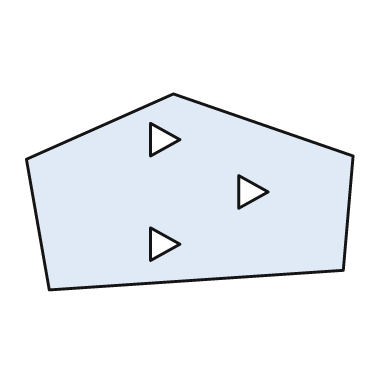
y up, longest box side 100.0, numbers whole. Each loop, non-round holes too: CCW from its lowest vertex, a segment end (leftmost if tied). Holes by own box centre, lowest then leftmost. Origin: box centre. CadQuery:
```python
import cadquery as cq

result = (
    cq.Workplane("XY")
    .moveTo(-43.0, -30.0)
    .lineTo(47.0, -24.0)
    .lineTo(50.0, 11.0)
    .lineTo(-5.0, 30.0)
    .lineTo(-50.0, 10.0)
    .close()
    .moveTo(-12.0, -21.0)
    .lineTo(-3.0, -16.0)
    .lineTo(-12.0, -11.0)
    .close()
    .moveTo(15.0, -5.0)
    .lineTo(24.0, 0.0)
    .lineTo(15.0, 5.0)
    .close()
    .moveTo(-12.0, 11.0)
    .lineTo(-3.0, 16.0)
    .lineTo(-12.0, 21.0)
    .close()
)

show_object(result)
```